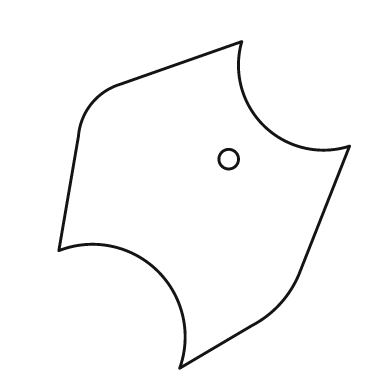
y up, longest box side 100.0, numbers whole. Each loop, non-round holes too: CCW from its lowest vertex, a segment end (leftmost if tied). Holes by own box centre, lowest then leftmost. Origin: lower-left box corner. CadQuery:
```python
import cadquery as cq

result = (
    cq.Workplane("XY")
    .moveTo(37.0, 0.0)
    .lineTo(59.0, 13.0)
    .threePointArc((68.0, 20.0), (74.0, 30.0))
    .lineTo(89.0, 68.0)
    .threePointArc((63.0, 74.0), (56.0, 100.0))
    .lineTo(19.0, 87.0)
    .threePointArc((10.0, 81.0), (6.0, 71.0))
    .lineTo(0.0, 36.0)
    .threePointArc((30.0, 30.0), (37.0, 0.0))
    .close()
    .moveTo(52.0, 64.0)
    .circle(3.0)
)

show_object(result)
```